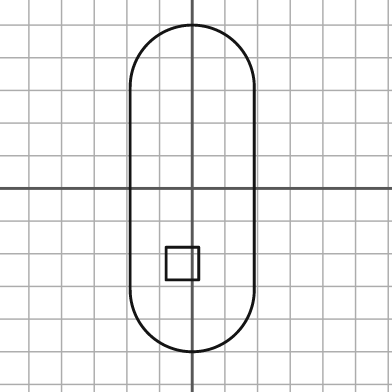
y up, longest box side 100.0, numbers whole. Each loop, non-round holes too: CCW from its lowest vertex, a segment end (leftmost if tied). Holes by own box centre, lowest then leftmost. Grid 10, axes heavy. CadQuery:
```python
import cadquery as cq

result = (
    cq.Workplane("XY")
    .moveTo(-19.0, -31.0)
    .threePointArc((0.0, -50.0), (19.0, -31.0))
    .lineTo(19.0, 31.0)
    .threePointArc((0.0, 50.0), (-19.0, 31.0))
    .close()
    .moveTo(-8.0, -28.0)
    .lineTo(2.0, -28.0)
    .lineTo(2.0, -18.0)
    .lineTo(-8.0, -18.0)
    .close()
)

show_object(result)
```